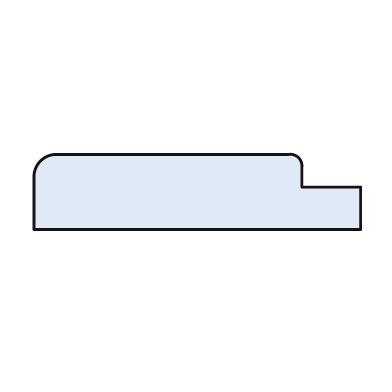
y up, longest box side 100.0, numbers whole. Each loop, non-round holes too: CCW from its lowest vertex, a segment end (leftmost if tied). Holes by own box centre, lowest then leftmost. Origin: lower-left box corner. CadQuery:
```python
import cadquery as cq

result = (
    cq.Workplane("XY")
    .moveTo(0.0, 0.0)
    .lineTo(100.0, 0.0)
    .lineTo(100.0, 13.0)
    .lineTo(82.0, 13.0)
    .lineTo(82.0, 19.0)
    .threePointArc((81.0, 22.0), (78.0, 23.0))
    .lineTo(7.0, 23.0)
    .threePointArc((2.0, 21.0), (0.0, 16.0))
    .close()
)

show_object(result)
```